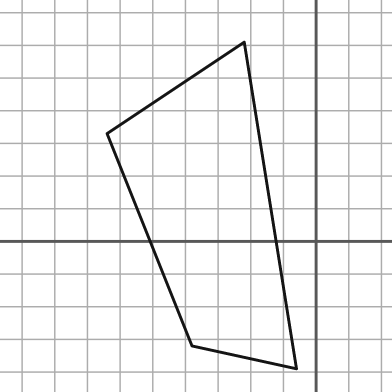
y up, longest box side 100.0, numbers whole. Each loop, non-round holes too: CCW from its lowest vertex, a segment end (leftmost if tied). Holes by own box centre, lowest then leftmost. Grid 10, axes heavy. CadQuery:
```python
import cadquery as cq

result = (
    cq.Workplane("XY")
    .moveTo(-6.0, -39.0)
    .lineTo(-22.0, 61.0)
    .lineTo(-64.0, 33.0)
    .lineTo(-38.0, -32.0)
    .close()
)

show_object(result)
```